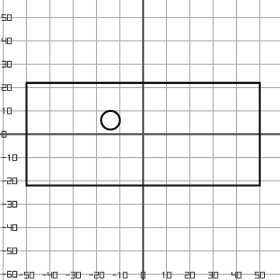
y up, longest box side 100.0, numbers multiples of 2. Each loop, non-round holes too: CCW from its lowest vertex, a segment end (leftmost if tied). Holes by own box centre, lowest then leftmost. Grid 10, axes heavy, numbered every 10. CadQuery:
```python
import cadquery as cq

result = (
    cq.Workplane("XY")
    .moveTo(-50.0, -22.0)
    .lineTo(50.0, -22.0)
    .lineTo(50.0, 22.0)
    .lineTo(-50.0, 22.0)
    .close()
    .moveTo(-14.0, 6.0)
    .circle(4.0)
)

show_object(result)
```